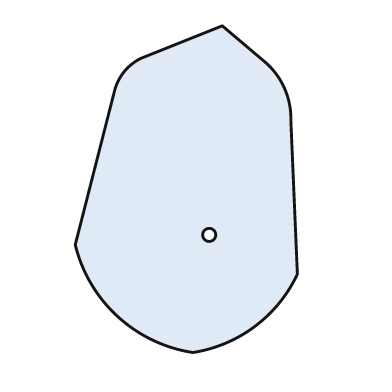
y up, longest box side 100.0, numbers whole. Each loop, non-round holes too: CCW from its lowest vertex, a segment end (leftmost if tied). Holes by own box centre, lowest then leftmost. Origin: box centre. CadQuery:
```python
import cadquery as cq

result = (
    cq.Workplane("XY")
    .moveTo(2.0, -50.0)
    .threePointArc((21.0, -42.0), (34.0, -26.0))
    .lineTo(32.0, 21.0)
    .threePointArc((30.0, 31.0), (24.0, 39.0))
    .lineTo(11.0, 50.0)
    .lineTo(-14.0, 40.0)
    .threePointArc((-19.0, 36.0), (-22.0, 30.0))
    .lineTo(-34.0, -17.0)
    .threePointArc((-21.0, -39.0), (2.0, -50.0))
    .close()
    .moveTo(7.0, -14.0)
    .circle(2.0)
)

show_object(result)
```